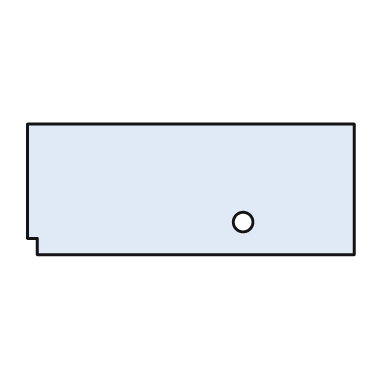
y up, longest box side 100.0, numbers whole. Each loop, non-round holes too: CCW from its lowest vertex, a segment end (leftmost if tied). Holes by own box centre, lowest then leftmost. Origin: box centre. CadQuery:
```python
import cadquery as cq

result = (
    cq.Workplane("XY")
    .moveTo(-47.0, -20.0)
    .lineTo(50.0, -20.0)
    .lineTo(50.0, 20.0)
    .lineTo(-50.0, 20.0)
    .lineTo(-50.0, -15.0)
    .lineTo(-47.0, -15.0)
    .close()
    .moveTo(16.0, -10.0)
    .circle(3.0)
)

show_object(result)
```